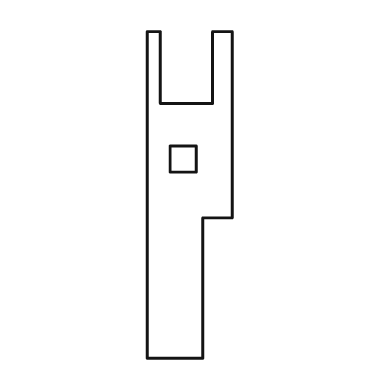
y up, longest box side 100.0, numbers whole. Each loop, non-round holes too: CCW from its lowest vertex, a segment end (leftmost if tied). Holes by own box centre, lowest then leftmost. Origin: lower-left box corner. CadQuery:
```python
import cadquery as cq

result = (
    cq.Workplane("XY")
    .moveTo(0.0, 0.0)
    .lineTo(17.0, 0.0)
    .lineTo(17.0, 43.0)
    .lineTo(26.0, 43.0)
    .lineTo(26.0, 100.0)
    .lineTo(20.0, 100.0)
    .lineTo(20.0, 78.0)
    .lineTo(4.0, 78.0)
    .lineTo(4.0, 100.0)
    .lineTo(0.0, 100.0)
    .close()
    .moveTo(7.0, 57.0)
    .lineTo(15.0, 57.0)
    .lineTo(15.0, 65.0)
    .lineTo(7.0, 65.0)
    .close()
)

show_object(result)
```